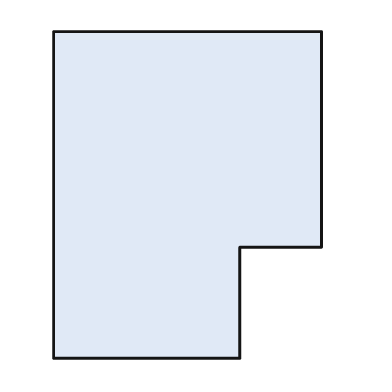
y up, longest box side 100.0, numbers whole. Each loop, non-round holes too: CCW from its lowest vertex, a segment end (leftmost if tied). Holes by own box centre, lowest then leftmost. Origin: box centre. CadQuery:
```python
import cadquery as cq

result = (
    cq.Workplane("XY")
    .moveTo(-41.0, -50.0)
    .lineTo(16.0, -50.0)
    .lineTo(16.0, -16.0)
    .lineTo(41.0, -16.0)
    .lineTo(41.0, 50.0)
    .lineTo(-41.0, 50.0)
    .close()
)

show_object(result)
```